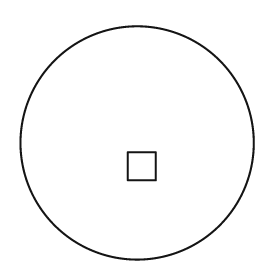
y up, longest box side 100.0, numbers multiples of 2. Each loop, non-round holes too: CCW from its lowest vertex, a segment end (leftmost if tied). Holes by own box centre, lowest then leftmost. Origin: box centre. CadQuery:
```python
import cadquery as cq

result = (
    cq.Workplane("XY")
    .moveTo(0.0, 0.0)
    .circle(50.0)
    .moveTo(-4.0, -16.0)
    .lineTo(8.0, -16.0)
    .lineTo(8.0, -4.0)
    .lineTo(-4.0, -4.0)
    .close()
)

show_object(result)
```